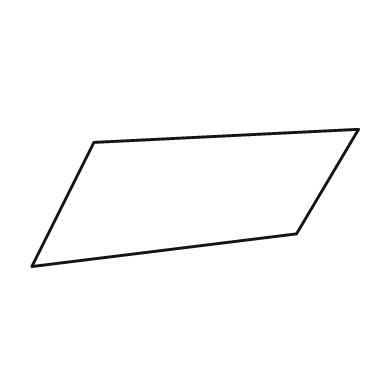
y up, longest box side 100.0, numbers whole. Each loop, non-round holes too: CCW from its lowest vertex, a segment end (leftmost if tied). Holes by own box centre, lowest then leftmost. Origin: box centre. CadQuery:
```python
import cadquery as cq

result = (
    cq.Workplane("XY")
    .moveTo(-50.0, -21.0)
    .lineTo(31.0, -11.0)
    .lineTo(50.0, 21.0)
    .lineTo(-31.0, 17.0)
    .close()
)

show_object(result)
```